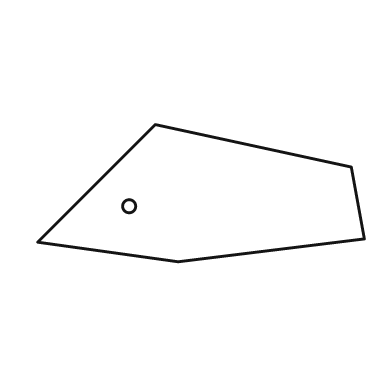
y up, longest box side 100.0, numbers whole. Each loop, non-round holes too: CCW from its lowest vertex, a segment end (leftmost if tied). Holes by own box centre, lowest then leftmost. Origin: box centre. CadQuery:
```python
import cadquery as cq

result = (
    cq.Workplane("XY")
    .moveTo(-7.0, -21.0)
    .lineTo(50.0, -14.0)
    .lineTo(46.0, 8.0)
    .lineTo(-14.0, 21.0)
    .lineTo(-50.0, -15.0)
    .close()
    .moveTo(-22.0, -4.0)
    .circle(2.0)
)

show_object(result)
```